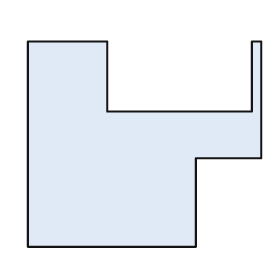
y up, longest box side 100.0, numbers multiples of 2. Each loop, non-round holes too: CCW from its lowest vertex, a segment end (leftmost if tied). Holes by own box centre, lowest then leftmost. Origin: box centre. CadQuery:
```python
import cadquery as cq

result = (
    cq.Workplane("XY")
    .moveTo(-50.0, -44.0)
    .lineTo(22.0, -44.0)
    .lineTo(22.0, -6.0)
    .lineTo(50.0, -6.0)
    .lineTo(50.0, 44.0)
    .lineTo(46.0, 44.0)
    .lineTo(46.0, 14.0)
    .lineTo(-16.0, 14.0)
    .lineTo(-16.0, 44.0)
    .lineTo(-50.0, 44.0)
    .close()
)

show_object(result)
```